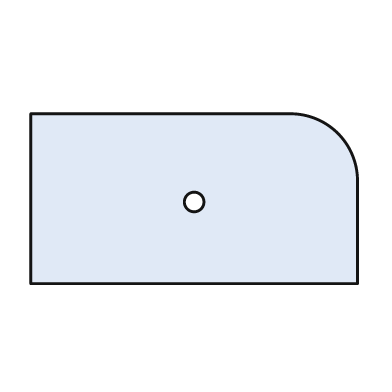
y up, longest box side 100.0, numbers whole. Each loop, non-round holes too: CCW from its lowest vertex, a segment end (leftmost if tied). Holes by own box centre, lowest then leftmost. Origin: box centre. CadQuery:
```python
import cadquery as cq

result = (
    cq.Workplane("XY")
    .moveTo(-50.0, -26.0)
    .lineTo(50.0, -26.0)
    .lineTo(50.0, 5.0)
    .threePointArc((44.0, 20.0), (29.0, 26.0))
    .lineTo(-50.0, 26.0)
    .close()
    .moveTo(0.0, -1.0)
    .circle(3.0)
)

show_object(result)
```